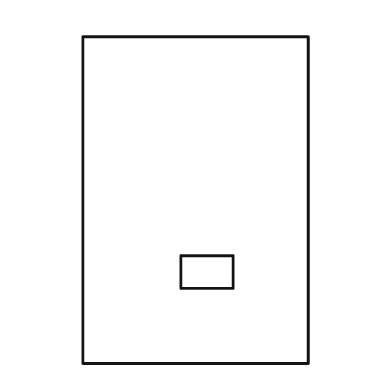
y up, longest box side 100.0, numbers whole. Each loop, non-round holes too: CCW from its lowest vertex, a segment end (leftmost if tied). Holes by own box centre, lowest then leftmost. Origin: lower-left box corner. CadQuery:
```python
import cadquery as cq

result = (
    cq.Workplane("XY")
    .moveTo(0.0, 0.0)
    .lineTo(69.0, 0.0)
    .lineTo(69.0, 100.0)
    .lineTo(0.0, 100.0)
    .close()
    .moveTo(30.0, 23.0)
    .lineTo(46.0, 23.0)
    .lineTo(46.0, 33.0)
    .lineTo(30.0, 33.0)
    .close()
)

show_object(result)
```